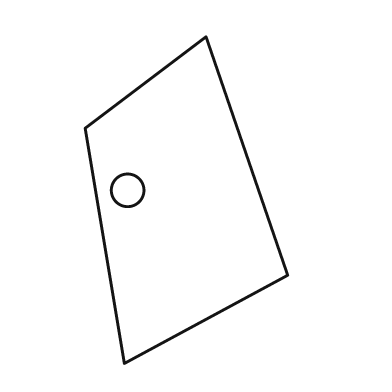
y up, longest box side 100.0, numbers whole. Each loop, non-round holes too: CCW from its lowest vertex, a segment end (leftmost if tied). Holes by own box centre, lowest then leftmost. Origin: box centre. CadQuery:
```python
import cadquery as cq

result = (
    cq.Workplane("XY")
    .moveTo(-19.0, -50.0)
    .lineTo(31.0, -23.0)
    .lineTo(6.0, 50.0)
    .lineTo(-31.0, 22.0)
    .close()
    .moveTo(-18.0, 3.0)
    .circle(5.0)
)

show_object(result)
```